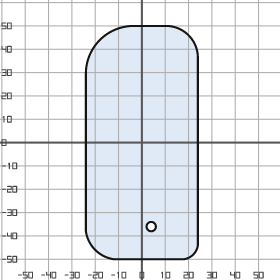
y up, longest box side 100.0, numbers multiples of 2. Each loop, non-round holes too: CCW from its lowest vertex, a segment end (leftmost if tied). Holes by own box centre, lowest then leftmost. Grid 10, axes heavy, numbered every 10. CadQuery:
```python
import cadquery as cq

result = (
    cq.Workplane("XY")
    .moveTo(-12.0, -50.0)
    .lineTo(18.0, -50.0)
    .threePointArc((22.0, -48.0), (24.0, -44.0))
    .lineTo(24.0, 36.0)
    .threePointArc((20.0, 46.0), (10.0, 50.0))
    .lineTo(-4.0, 50.0)
    .threePointArc((-18.0, 44.0), (-24.0, 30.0))
    .lineTo(-24.0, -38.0)
    .threePointArc((-20.0, -46.0), (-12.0, -50.0))
    .close()
    .moveTo(4.0, -36.0)
    .circle(2.0)
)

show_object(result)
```